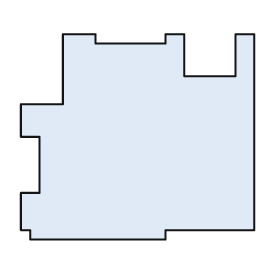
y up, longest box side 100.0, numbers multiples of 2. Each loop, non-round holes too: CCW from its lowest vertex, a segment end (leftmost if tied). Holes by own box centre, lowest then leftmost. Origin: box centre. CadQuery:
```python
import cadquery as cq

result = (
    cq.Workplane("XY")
    .moveTo(-46.0, -44.0)
    .lineTo(12.0, -44.0)
    .lineTo(12.0, -40.0)
    .lineTo(50.0, -40.0)
    .lineTo(50.0, 44.0)
    .lineTo(42.0, 44.0)
    .lineTo(42.0, 26.0)
    .lineTo(20.0, 26.0)
    .lineTo(20.0, 44.0)
    .lineTo(12.0, 44.0)
    .lineTo(12.0, 40.0)
    .lineTo(-18.0, 40.0)
    .lineTo(-18.0, 44.0)
    .lineTo(-32.0, 44.0)
    .lineTo(-32.0, 14.0)
    .lineTo(-50.0, 14.0)
    .lineTo(-50.0, 0.0)
    .lineTo(-42.0, 0.0)
    .lineTo(-42.0, -24.0)
    .lineTo(-50.0, -24.0)
    .lineTo(-50.0, -40.0)
    .lineTo(-46.0, -40.0)
    .close()
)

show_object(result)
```